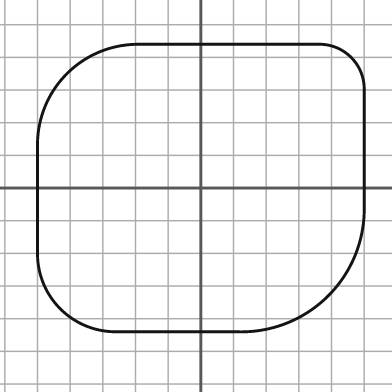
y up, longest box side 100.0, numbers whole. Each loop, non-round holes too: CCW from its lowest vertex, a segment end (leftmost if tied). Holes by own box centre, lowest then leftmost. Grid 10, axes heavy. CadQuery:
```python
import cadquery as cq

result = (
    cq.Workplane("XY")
    .moveTo(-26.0, -44.0)
    .lineTo(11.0, -44.0)
    .threePointArc((39.0, -33.0), (50.0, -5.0))
    .lineTo(50.0, 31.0)
    .threePointArc((46.0, 40.0), (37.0, 44.0))
    .lineTo(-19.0, 44.0)
    .threePointArc((-41.0, 35.0), (-50.0, 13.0))
    .lineTo(-50.0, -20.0)
    .threePointArc((-43.0, -37.0), (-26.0, -44.0))
    .close()
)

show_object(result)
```